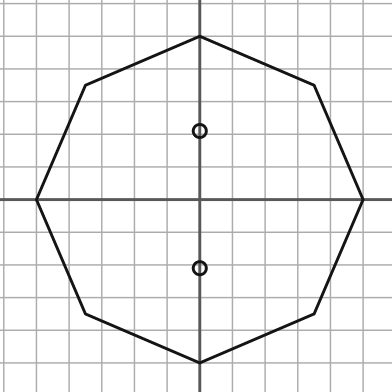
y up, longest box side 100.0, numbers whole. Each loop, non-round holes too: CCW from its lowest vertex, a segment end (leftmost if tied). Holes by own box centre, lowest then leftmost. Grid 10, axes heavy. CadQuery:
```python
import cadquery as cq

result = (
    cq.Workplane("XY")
    .moveTo(0.0, -50.0)
    .lineTo(35.0, -35.0)
    .lineTo(50.0, 0.0)
    .lineTo(35.0, 35.0)
    .lineTo(0.0, 50.0)
    .lineTo(-35.0, 35.0)
    .lineTo(-50.0, 0.0)
    .lineTo(-35.0, -35.0)
    .close()
    .moveTo(0.0, -21.0)
    .circle(2.0)
    .moveTo(0.0, 21.0)
    .circle(2.0)
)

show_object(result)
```